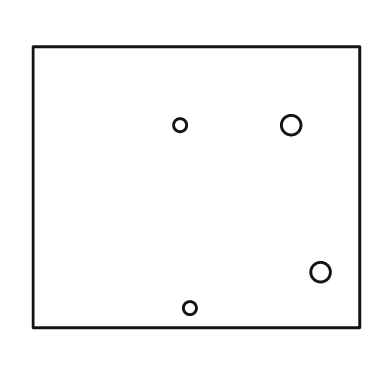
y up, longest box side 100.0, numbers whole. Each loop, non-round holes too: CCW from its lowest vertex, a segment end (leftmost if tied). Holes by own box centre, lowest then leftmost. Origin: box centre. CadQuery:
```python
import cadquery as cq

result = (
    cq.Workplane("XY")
    .moveTo(-50.0, -43.0)
    .lineTo(50.0, -43.0)
    .lineTo(50.0, 43.0)
    .lineTo(-50.0, 43.0)
    .close()
    .moveTo(-2.0, -37.0)
    .circle(2.0)
    .moveTo(38.0, -26.0)
    .circle(3.0)
    .moveTo(-5.0, 19.0)
    .circle(2.0)
    .moveTo(29.0, 19.0)
    .circle(3.0)
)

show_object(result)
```